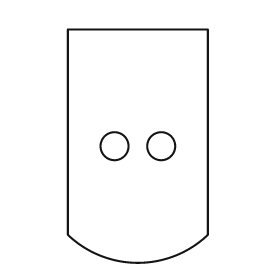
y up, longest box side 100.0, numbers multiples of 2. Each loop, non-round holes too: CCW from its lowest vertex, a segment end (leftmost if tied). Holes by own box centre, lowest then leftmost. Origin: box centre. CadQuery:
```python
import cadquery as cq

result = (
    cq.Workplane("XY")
    .moveTo(-30.0, -38.0)
    .threePointArc((0.0, -50.0), (30.0, -38.0))
    .lineTo(30.0, 50.0)
    .lineTo(-30.0, 50.0)
    .close()
    .moveTo(-10.0, 0.0)
    .circle(6.0)
    .moveTo(10.0, 0.0)
    .circle(6.0)
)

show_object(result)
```